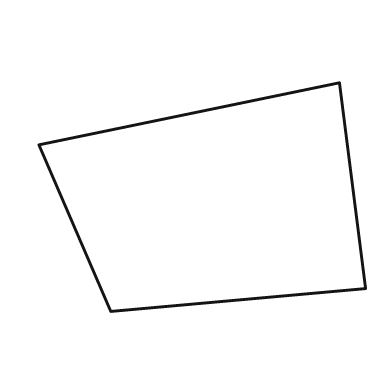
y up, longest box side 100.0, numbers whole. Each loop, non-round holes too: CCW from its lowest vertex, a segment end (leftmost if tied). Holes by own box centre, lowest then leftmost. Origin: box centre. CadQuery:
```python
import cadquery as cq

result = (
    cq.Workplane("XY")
    .moveTo(-28.0, -35.0)
    .lineTo(50.0, -28.0)
    .lineTo(42.0, 35.0)
    .lineTo(-50.0, 16.0)
    .close()
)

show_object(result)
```